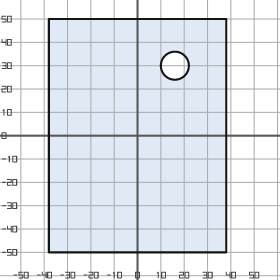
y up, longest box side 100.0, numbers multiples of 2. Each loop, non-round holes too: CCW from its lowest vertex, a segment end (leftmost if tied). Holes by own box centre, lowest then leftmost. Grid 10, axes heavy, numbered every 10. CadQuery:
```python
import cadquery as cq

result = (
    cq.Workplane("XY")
    .moveTo(-38.0, -50.0)
    .lineTo(38.0, -50.0)
    .lineTo(38.0, 50.0)
    .lineTo(-38.0, 50.0)
    .close()
    .moveTo(16.0, 30.0)
    .circle(6.0)
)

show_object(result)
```